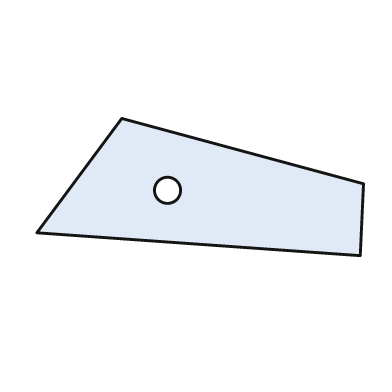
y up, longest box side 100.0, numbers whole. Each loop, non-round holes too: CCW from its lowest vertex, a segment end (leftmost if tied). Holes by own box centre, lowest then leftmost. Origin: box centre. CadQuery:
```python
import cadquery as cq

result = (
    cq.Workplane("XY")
    .moveTo(49.0, -21.0)
    .lineTo(50.0, 1.0)
    .lineTo(-24.0, 21.0)
    .lineTo(-50.0, -14.0)
    .close()
    .moveTo(-10.0, -1.0)
    .circle(4.0)
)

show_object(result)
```